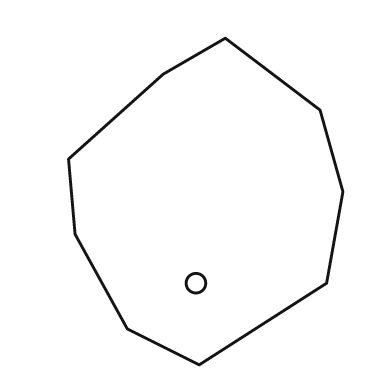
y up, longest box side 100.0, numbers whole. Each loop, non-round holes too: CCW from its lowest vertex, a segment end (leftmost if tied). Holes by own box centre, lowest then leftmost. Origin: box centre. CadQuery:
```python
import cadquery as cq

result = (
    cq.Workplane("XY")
    .moveTo(-2.0, -50.0)
    .lineTo(37.0, -25.0)
    .lineTo(42.0, 3.0)
    .lineTo(35.0, 28.0)
    .lineTo(6.0, 50.0)
    .lineTo(-13.0, 39.0)
    .lineTo(-42.0, 13.0)
    .lineTo(-40.0, -10.0)
    .lineTo(-24.0, -39.0)
    .close()
    .moveTo(-3.0, -25.0)
    .circle(3.0)
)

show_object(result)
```